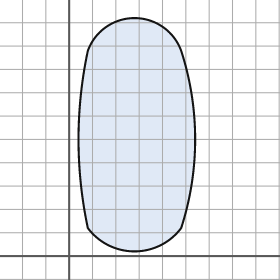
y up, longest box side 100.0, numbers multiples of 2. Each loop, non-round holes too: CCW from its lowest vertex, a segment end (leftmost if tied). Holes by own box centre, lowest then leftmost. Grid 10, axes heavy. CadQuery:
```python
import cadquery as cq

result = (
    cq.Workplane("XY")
    .moveTo(8.0, 12.0)
    .threePointArc((28.0, 2.0), (48.0, 12.0))
    .threePointArc((54.0, 50.0), (48.0, 88.0))
    .threePointArc((28.0, 102.0), (8.0, 88.0))
    .threePointArc((4.0, 50.0), (8.0, 12.0))
    .close()
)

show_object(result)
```